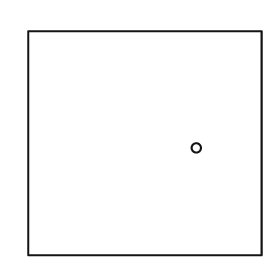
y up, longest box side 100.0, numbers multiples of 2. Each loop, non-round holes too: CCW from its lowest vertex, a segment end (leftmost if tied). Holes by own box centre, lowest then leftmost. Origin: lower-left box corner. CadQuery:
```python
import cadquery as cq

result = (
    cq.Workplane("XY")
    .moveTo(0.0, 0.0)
    .lineTo(100.0, 0.0)
    .lineTo(100.0, 96.0)
    .lineTo(0.0, 96.0)
    .close()
    .moveTo(72.0, 46.0)
    .circle(2.0)
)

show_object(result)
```